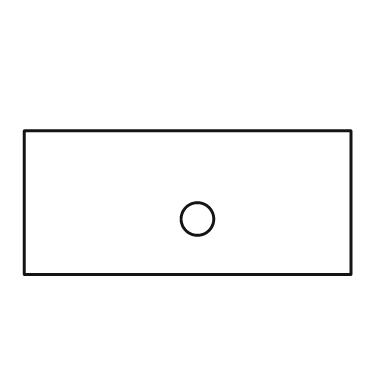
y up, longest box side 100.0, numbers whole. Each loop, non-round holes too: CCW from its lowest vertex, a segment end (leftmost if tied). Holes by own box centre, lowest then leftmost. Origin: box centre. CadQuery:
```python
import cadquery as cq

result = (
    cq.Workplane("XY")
    .moveTo(-50.0, -22.0)
    .lineTo(50.0, -22.0)
    .lineTo(50.0, 22.0)
    .lineTo(-50.0, 22.0)
    .close()
    .moveTo(3.0, -5.0)
    .circle(5.0)
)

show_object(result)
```